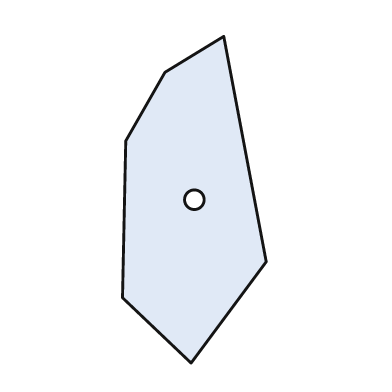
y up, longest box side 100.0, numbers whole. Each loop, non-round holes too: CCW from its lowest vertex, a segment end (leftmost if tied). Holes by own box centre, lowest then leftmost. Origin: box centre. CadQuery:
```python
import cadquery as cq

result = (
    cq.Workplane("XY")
    .moveTo(-1.0, -50.0)
    .lineTo(22.0, -19.0)
    .lineTo(9.0, 50.0)
    .lineTo(-9.0, 39.0)
    .lineTo(-21.0, 18.0)
    .lineTo(-22.0, -30.0)
    .close()
    .moveTo(0.0, 0.0)
    .circle(3.0)
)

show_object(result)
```